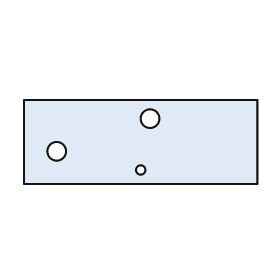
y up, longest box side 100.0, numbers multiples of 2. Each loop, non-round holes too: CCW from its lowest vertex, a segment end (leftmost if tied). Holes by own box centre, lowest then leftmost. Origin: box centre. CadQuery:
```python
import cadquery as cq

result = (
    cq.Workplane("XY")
    .moveTo(-50.0, -18.0)
    .lineTo(50.0, -18.0)
    .lineTo(50.0, 18.0)
    .lineTo(-50.0, 18.0)
    .close()
    .moveTo(0.0, -12.0)
    .circle(2.0)
    .moveTo(-36.0, -4.0)
    .circle(4.0)
    .moveTo(4.0, 10.0)
    .circle(4.0)
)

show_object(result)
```